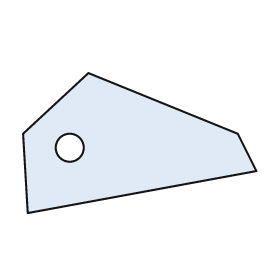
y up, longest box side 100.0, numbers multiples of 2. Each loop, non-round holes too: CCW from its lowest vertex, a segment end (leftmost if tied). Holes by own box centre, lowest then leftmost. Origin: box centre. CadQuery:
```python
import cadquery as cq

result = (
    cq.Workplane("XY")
    .moveTo(-48.0, -30.0)
    .lineTo(50.0, -12.0)
    .lineTo(42.0, 4.0)
    .lineTo(-22.0, 30.0)
    .lineTo(-50.0, 4.0)
    .close()
    .moveTo(-30.0, -2.0)
    .circle(6.0)
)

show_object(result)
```